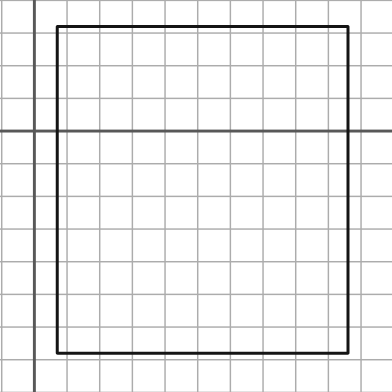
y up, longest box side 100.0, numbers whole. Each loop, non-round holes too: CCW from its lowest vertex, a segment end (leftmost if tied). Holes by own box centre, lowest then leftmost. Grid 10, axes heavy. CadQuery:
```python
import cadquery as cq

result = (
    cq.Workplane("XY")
    .moveTo(7.0, -68.0)
    .lineTo(96.0, -68.0)
    .lineTo(96.0, 32.0)
    .lineTo(7.0, 32.0)
    .close()
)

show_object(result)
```